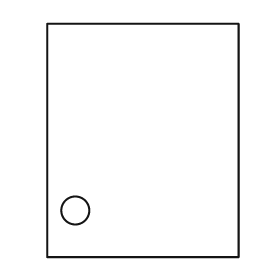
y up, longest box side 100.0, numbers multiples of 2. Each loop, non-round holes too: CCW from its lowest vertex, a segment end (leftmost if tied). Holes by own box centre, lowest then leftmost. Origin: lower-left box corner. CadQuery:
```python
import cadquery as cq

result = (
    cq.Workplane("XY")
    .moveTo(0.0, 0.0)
    .lineTo(82.0, 0.0)
    .lineTo(82.0, 100.0)
    .lineTo(0.0, 100.0)
    .close()
    .moveTo(12.0, 20.0)
    .circle(6.0)
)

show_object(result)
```